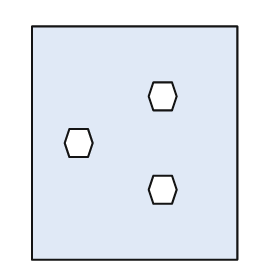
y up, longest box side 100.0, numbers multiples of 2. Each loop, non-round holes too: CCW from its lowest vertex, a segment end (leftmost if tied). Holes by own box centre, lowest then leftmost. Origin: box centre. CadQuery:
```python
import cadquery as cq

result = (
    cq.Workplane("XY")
    .moveTo(-44.0, -50.0)
    .lineTo(44.0, -50.0)
    .lineTo(44.0, 50.0)
    .lineTo(-44.0, 50.0)
    .close()
    .moveTo(8.0, -26.0)
    .lineTo(16.0, -26.0)
    .lineTo(18.0, -20.0)
    .lineTo(16.0, -14.0)
    .lineTo(8.0, -14.0)
    .lineTo(6.0, -20.0)
    .close()
    .moveTo(-28.0, -6.0)
    .lineTo(-20.0, -6.0)
    .lineTo(-18.0, 0.0)
    .lineTo(-20.0, 6.0)
    .lineTo(-28.0, 6.0)
    .lineTo(-30.0, 0.0)
    .close()
    .moveTo(8.0, 14.0)
    .lineTo(16.0, 14.0)
    .lineTo(18.0, 20.0)
    .lineTo(16.0, 26.0)
    .lineTo(8.0, 26.0)
    .lineTo(6.0, 20.0)
    .close()
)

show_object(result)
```